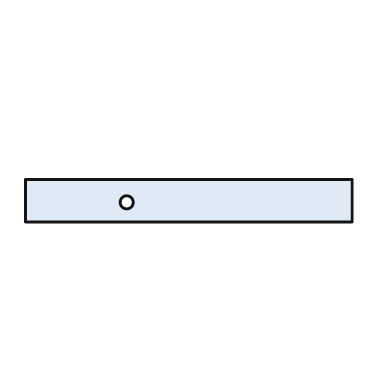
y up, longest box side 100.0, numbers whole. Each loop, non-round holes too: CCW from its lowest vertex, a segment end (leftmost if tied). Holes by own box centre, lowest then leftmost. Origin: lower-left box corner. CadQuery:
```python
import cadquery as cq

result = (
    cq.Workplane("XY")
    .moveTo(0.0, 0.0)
    .lineTo(100.0, 0.0)
    .lineTo(100.0, 13.0)
    .lineTo(0.0, 13.0)
    .close()
    .moveTo(31.0, 6.0)
    .circle(2.0)
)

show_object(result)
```